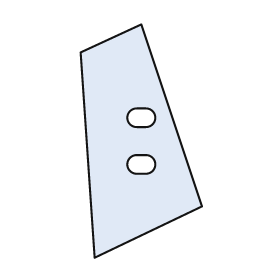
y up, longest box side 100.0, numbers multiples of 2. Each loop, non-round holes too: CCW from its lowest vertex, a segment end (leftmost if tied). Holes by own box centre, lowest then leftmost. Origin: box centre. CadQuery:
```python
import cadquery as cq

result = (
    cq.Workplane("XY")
    .moveTo(-20.0, -50.0)
    .lineTo(26.0, -28.0)
    .lineTo(0.0, 50.0)
    .lineTo(-26.0, 38.0)
    .close()
    .moveTo(-2.0, -14.0)
    .lineTo(2.0, -14.0)
    .threePointArc((6.0, -10.0), (2.0, -6.0))
    .lineTo(-2.0, -6.0)
    .threePointArc((-6.0, -10.0), (-2.0, -14.0))
    .close()
    .moveTo(-2.0, 6.0)
    .lineTo(2.0, 6.0)
    .threePointArc((6.0, 10.0), (2.0, 14.0))
    .lineTo(-2.0, 14.0)
    .threePointArc((-6.0, 10.0), (-2.0, 6.0))
    .close()
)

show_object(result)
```